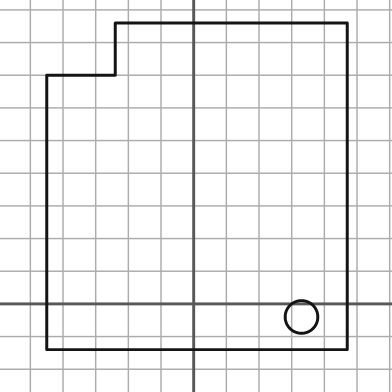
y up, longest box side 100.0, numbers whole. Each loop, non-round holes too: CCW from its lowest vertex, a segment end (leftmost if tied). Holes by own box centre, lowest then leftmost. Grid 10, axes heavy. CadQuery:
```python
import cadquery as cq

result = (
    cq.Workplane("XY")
    .moveTo(-45.0, -14.0)
    .lineTo(47.0, -14.0)
    .lineTo(47.0, 86.0)
    .lineTo(-24.0, 86.0)
    .lineTo(-24.0, 70.0)
    .lineTo(-45.0, 70.0)
    .close()
    .moveTo(33.0, -4.0)
    .circle(5.0)
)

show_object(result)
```